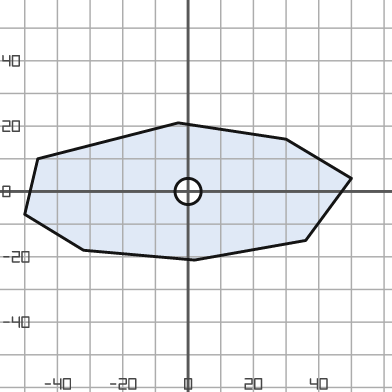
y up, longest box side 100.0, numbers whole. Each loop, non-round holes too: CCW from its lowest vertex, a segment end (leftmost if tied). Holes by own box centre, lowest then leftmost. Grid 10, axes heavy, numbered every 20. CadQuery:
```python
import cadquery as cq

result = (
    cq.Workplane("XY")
    .moveTo(2.0, -21.0)
    .lineTo(36.0, -15.0)
    .lineTo(50.0, 4.0)
    .lineTo(30.0, 16.0)
    .lineTo(-3.0, 21.0)
    .lineTo(-46.0, 10.0)
    .lineTo(-50.0, -7.0)
    .lineTo(-32.0, -18.0)
    .close()
    .moveTo(0.0, 0.0)
    .circle(4.0)
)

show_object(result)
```